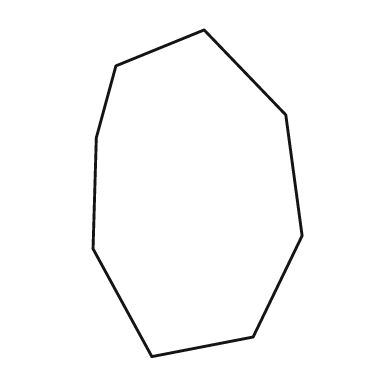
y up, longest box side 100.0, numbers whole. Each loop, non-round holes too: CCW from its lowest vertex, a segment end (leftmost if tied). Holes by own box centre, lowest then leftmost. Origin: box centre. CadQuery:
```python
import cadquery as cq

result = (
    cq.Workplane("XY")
    .moveTo(-14.0, -50.0)
    .lineTo(17.0, -44.0)
    .lineTo(32.0, -13.0)
    .lineTo(27.0, 24.0)
    .lineTo(2.0, 50.0)
    .lineTo(-25.0, 39.0)
    .lineTo(-31.0, 17.0)
    .lineTo(-32.0, -17.0)
    .close()
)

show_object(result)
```